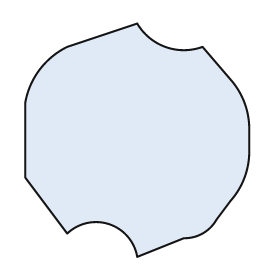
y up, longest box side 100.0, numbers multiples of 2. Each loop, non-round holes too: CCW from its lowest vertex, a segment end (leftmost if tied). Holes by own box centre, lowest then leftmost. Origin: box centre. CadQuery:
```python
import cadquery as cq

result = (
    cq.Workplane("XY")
    .moveTo(0.0, -50.0)
    .lineTo(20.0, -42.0)
    .threePointArc((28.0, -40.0), (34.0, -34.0))
    .lineTo(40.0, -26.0)
    .threePointArc((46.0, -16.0), (48.0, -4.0))
    .lineTo(48.0, 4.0)
    .threePointArc((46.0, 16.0), (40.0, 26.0))
    .lineTo(28.0, 40.0)
    .threePointArc((12.0, 40.0), (0.0, 50.0))
    .lineTo(-30.0, 40.0)
    .threePointArc((-42.0, 30.0), (-48.0, 16.0))
    .lineTo(-48.0, -16.0)
    .lineTo(-30.0, -40.0)
    .threePointArc((-12.0, -36.0), (0.0, -50.0))
    .close()
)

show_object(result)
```